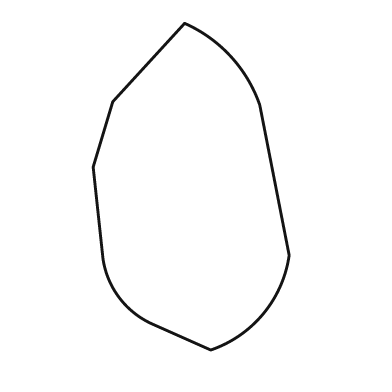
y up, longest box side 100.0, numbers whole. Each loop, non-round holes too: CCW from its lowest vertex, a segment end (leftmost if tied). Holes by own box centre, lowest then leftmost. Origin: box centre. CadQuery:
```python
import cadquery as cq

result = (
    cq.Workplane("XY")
    .moveTo(6.0, -50.0)
    .threePointArc((22.0, -39.0), (30.0, -21.0))
    .lineTo(21.0, 25.0)
    .threePointArc((12.0, 40.0), (-2.0, 50.0))
    .lineTo(-24.0, 26.0)
    .lineTo(-30.0, 6.0)
    .lineTo(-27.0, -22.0)
    .threePointArc((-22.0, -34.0), (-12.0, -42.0))
    .close()
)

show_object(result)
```